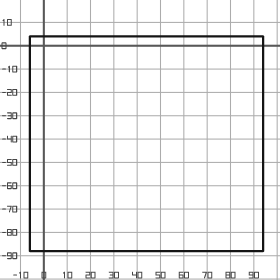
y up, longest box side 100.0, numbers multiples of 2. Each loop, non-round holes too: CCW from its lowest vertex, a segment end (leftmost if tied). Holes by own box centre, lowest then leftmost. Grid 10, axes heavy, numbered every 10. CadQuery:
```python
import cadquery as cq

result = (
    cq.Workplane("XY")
    .moveTo(-6.0, -88.0)
    .lineTo(94.0, -88.0)
    .lineTo(94.0, 4.0)
    .lineTo(-6.0, 4.0)
    .close()
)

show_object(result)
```